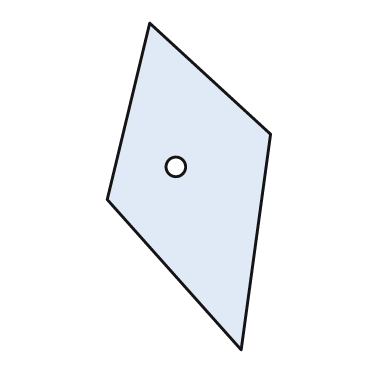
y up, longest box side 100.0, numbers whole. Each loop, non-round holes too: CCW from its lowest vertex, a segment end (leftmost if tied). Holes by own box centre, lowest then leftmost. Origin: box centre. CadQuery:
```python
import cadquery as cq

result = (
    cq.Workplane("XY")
    .moveTo(16.0, -50.0)
    .lineTo(25.0, 16.0)
    .lineTo(-12.0, 50.0)
    .lineTo(-25.0, -4.0)
    .close()
    .moveTo(-4.0, 6.0)
    .circle(3.0)
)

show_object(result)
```